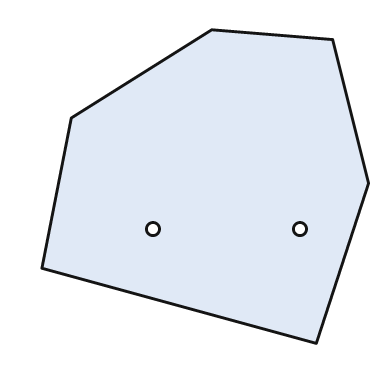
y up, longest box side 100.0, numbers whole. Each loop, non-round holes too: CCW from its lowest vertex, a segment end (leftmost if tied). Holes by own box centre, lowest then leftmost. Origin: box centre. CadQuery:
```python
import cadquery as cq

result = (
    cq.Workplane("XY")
    .moveTo(34.0, -48.0)
    .lineTo(50.0, 1.0)
    .lineTo(39.0, 45.0)
    .lineTo(2.0, 48.0)
    .lineTo(-41.0, 21.0)
    .lineTo(-50.0, -25.0)
    .close()
    .moveTo(-16.0, -13.0)
    .circle(2.0)
    .moveTo(29.0, -13.0)
    .circle(2.0)
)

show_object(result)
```